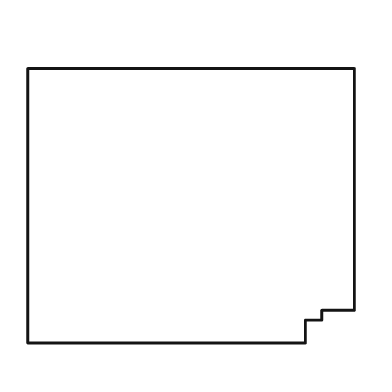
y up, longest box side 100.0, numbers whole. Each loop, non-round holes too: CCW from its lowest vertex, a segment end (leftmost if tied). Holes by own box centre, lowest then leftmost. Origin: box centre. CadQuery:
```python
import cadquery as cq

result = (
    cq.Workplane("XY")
    .moveTo(-50.0, -42.0)
    .lineTo(35.0, -42.0)
    .lineTo(35.0, -35.0)
    .lineTo(40.0, -35.0)
    .lineTo(40.0, -32.0)
    .lineTo(50.0, -32.0)
    .lineTo(50.0, 42.0)
    .lineTo(-50.0, 42.0)
    .close()
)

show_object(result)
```